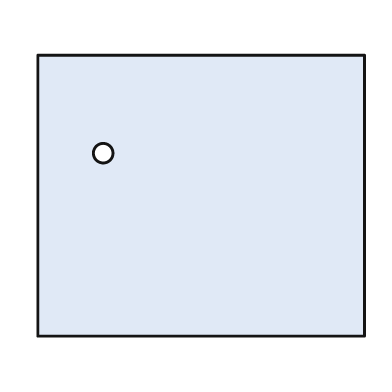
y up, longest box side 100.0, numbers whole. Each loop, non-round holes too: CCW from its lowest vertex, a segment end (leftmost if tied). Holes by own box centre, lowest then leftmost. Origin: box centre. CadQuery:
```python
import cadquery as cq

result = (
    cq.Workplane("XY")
    .moveTo(-50.0, -43.0)
    .lineTo(50.0, -43.0)
    .lineTo(50.0, 43.0)
    .lineTo(-50.0, 43.0)
    .close()
    .moveTo(-30.0, 13.0)
    .circle(3.0)
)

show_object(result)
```